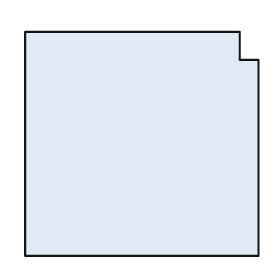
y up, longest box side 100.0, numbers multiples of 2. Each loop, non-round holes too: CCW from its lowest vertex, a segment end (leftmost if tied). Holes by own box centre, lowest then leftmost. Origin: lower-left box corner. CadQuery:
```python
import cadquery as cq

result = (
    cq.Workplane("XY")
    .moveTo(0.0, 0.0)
    .lineTo(100.0, 0.0)
    .lineTo(100.0, 84.0)
    .lineTo(92.0, 84.0)
    .lineTo(92.0, 96.0)
    .lineTo(0.0, 96.0)
    .close()
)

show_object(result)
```